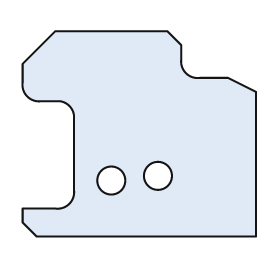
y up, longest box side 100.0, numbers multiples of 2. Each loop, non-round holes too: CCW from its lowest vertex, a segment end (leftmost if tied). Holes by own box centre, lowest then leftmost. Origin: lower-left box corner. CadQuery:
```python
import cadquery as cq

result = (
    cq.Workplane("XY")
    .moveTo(6.0, 0.0)
    .lineTo(100.0, 0.0)
    .lineTo(100.0, 62.0)
    .lineTo(88.0, 68.0)
    .lineTo(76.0, 68.0)
    .threePointArc((70.0, 70.0), (68.0, 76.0))
    .lineTo(68.0, 82.0)
    .lineTo(62.0, 88.0)
    .lineTo(14.0, 88.0)
    .lineTo(0.0, 74.0)
    .lineTo(0.0, 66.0)
    .threePointArc((2.0, 60.0), (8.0, 58.0))
    .lineTo(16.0, 58.0)
    .threePointArc((20.0, 56.0), (22.0, 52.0))
    .lineTo(22.0, 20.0)
    .threePointArc((20.0, 14.0), (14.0, 12.0))
    .lineTo(0.0, 12.0)
    .lineTo(0.0, 6.0)
    .close()
    .moveTo(38.0, 24.0)
    .circle(6.0)
    .moveTo(58.0, 26.0)
    .circle(6.0)
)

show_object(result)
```